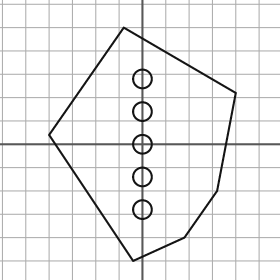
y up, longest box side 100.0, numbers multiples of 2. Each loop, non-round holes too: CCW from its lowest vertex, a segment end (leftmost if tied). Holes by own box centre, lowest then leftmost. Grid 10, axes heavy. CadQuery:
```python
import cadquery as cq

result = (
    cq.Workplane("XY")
    .moveTo(-4.0, -50.0)
    .lineTo(18.0, -40.0)
    .lineTo(32.0, -20.0)
    .lineTo(40.0, 22.0)
    .lineTo(-8.0, 50.0)
    .lineTo(-40.0, 4.0)
    .close()
    .moveTo(0.0, -28.0)
    .circle(4.0)
    .moveTo(0.0, -14.0)
    .circle(4.0)
    .moveTo(0.0, 0.0)
    .circle(4.0)
    .moveTo(0.0, 14.0)
    .circle(4.0)
    .moveTo(0.0, 28.0)
    .circle(4.0)
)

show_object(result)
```